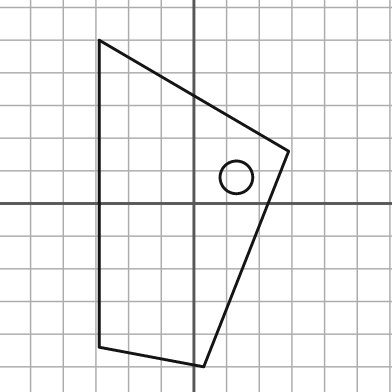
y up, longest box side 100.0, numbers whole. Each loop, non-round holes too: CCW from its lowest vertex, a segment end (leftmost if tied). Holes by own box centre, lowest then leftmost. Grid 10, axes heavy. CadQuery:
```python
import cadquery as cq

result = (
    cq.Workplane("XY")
    .moveTo(3.0, -50.0)
    .lineTo(29.0, 16.0)
    .lineTo(-29.0, 50.0)
    .lineTo(-29.0, -44.0)
    .close()
    .moveTo(13.0, 8.0)
    .circle(5.0)
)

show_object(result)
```